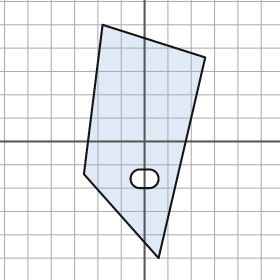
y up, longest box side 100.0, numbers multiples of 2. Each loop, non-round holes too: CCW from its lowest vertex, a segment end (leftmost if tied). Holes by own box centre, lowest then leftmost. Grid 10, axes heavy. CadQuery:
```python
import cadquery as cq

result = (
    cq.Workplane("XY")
    .moveTo(6.0, -50.0)
    .lineTo(26.0, 36.0)
    .lineTo(-18.0, 50.0)
    .lineTo(-26.0, -14.0)
    .close()
    .moveTo(-2.0, -20.0)
    .lineTo(2.0, -20.0)
    .threePointArc((6.0, -16.0), (2.0, -12.0))
    .lineTo(-2.0, -12.0)
    .threePointArc((-6.0, -16.0), (-2.0, -20.0))
    .close()
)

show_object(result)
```